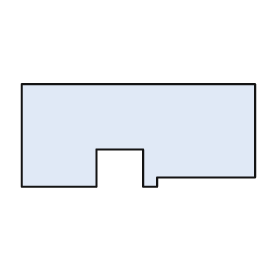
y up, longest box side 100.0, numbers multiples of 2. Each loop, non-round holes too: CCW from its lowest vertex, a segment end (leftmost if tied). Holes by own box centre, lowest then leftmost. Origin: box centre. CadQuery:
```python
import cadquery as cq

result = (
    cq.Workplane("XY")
    .moveTo(-50.0, -22.0)
    .lineTo(-18.0, -22.0)
    .lineTo(-18.0, -6.0)
    .lineTo(2.0, -6.0)
    .lineTo(2.0, -22.0)
    .lineTo(8.0, -22.0)
    .lineTo(8.0, -18.0)
    .lineTo(50.0, -18.0)
    .lineTo(50.0, 22.0)
    .lineTo(-50.0, 22.0)
    .close()
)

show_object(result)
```